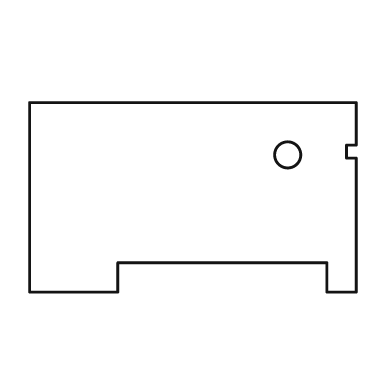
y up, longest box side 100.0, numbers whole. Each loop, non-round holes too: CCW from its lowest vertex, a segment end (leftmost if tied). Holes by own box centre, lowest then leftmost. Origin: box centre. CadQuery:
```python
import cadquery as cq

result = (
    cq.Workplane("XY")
    .moveTo(-50.0, -29.0)
    .lineTo(-23.0, -29.0)
    .lineTo(-23.0, -20.0)
    .lineTo(41.0, -20.0)
    .lineTo(41.0, -29.0)
    .lineTo(50.0, -29.0)
    .lineTo(50.0, 12.0)
    .lineTo(47.0, 12.0)
    .lineTo(47.0, 16.0)
    .lineTo(50.0, 16.0)
    .lineTo(50.0, 29.0)
    .lineTo(-50.0, 29.0)
    .close()
    .moveTo(29.0, 13.0)
    .circle(4.0)
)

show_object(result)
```